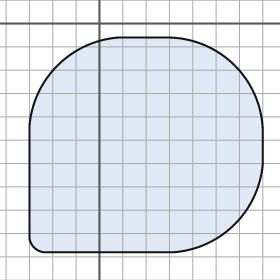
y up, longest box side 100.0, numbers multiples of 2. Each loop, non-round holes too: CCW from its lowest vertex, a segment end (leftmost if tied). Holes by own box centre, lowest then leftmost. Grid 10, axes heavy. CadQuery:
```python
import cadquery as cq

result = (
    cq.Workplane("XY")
    .moveTo(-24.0, -98.0)
    .lineTo(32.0, -98.0)
    .threePointArc((58.0, -86.0), (70.0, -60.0))
    .lineTo(70.0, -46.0)
    .threePointArc((58.0, -18.0), (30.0, -6.0))
    .lineTo(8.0, -6.0)
    .threePointArc((-18.0, -18.0), (-30.0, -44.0))
    .lineTo(-30.0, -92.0)
    .threePointArc((-28.0, -96.0), (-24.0, -98.0))
    .close()
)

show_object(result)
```